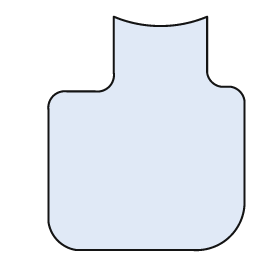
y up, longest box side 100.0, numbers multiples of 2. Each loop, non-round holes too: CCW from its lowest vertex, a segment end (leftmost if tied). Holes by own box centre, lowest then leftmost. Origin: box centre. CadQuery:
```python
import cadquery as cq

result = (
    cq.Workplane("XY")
    .moveTo(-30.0, -50.0)
    .lineTo(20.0, -50.0)
    .threePointArc((36.0, -44.0), (42.0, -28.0))
    .lineTo(42.0, 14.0)
    .threePointArc((40.0, 18.0), (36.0, 20.0))
    .lineTo(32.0, 20.0)
    .threePointArc((28.0, 22.0), (26.0, 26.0))
    .lineTo(26.0, 50.0)
    .threePointArc((6.0, 46.0), (-14.0, 50.0))
    .lineTo(-14.0, 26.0)
    .threePointArc((-16.0, 20.0), (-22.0, 18.0))
    .lineTo(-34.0, 18.0)
    .threePointArc((-40.0, 16.0), (-42.0, 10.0))
    .lineTo(-42.0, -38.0)
    .threePointArc((-38.0, -46.0), (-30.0, -50.0))
    .close()
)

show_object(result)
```